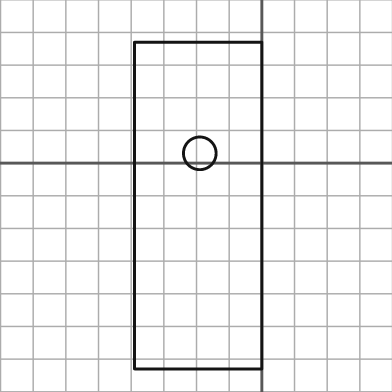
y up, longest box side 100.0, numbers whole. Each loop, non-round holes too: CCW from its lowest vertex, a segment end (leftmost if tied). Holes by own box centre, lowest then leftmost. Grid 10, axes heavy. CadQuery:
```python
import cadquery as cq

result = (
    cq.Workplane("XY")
    .moveTo(-39.0, -63.0)
    .lineTo(0.0, -63.0)
    .lineTo(0.0, 37.0)
    .lineTo(-39.0, 37.0)
    .close()
    .moveTo(-19.0, 3.0)
    .circle(5.0)
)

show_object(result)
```